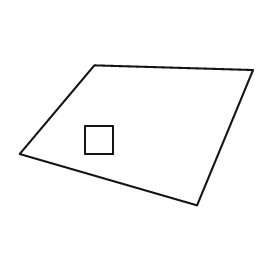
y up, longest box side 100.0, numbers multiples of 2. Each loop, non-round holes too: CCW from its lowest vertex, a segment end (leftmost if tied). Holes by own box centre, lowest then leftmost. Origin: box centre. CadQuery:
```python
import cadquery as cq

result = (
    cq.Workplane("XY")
    .moveTo(26.0, -30.0)
    .lineTo(50.0, 28.0)
    .lineTo(-18.0, 30.0)
    .lineTo(-50.0, -8.0)
    .close()
    .moveTo(-22.0, -8.0)
    .lineTo(-10.0, -8.0)
    .lineTo(-10.0, 4.0)
    .lineTo(-22.0, 4.0)
    .close()
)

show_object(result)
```